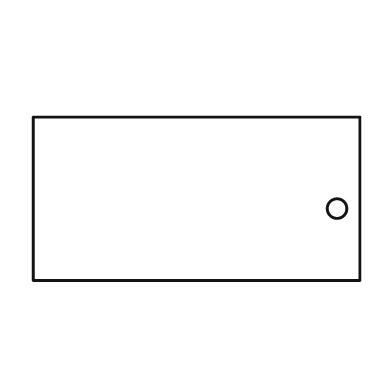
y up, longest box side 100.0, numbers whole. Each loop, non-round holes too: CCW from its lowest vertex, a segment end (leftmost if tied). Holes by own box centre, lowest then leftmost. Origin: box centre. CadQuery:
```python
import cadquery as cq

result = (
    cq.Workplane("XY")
    .moveTo(-50.0, -25.0)
    .lineTo(50.0, -25.0)
    .lineTo(50.0, 25.0)
    .lineTo(-50.0, 25.0)
    .close()
    .moveTo(43.0, -3.0)
    .circle(3.0)
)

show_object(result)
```